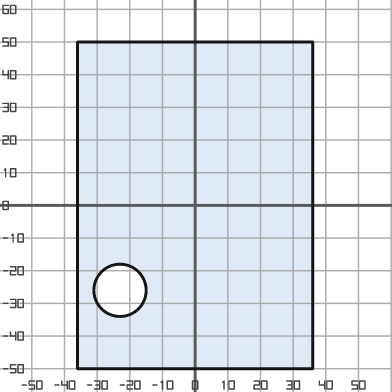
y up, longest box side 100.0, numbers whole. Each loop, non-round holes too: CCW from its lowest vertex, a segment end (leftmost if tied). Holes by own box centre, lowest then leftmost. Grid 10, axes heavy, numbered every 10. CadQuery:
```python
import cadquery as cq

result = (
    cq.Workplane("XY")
    .moveTo(-36.0, -50.0)
    .lineTo(36.0, -50.0)
    .lineTo(36.0, 50.0)
    .lineTo(-36.0, 50.0)
    .close()
    .moveTo(-23.0, -26.0)
    .circle(8.0)
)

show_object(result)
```